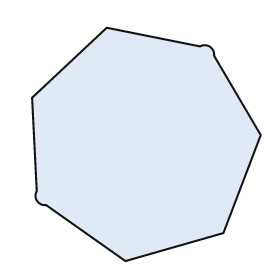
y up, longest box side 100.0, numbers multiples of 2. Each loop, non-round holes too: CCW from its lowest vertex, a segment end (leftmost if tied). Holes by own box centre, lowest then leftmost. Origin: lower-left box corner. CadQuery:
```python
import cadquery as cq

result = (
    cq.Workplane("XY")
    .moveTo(40.0, 0.0)
    .lineTo(82.0, 12.0)
    .lineTo(98.0, 54.0)
    .lineTo(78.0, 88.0)
    .threePointArc((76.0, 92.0), (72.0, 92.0))
    .lineTo(32.0, 100.0)
    .lineTo(0.0, 70.0)
    .lineTo(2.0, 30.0)
    .threePointArc((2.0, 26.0), (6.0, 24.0))
    .close()
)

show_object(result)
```